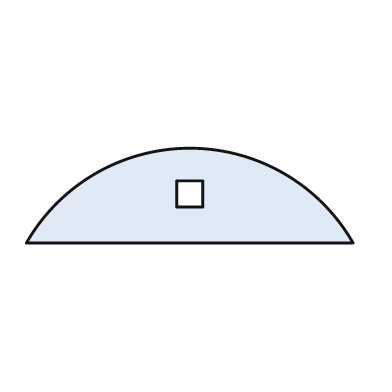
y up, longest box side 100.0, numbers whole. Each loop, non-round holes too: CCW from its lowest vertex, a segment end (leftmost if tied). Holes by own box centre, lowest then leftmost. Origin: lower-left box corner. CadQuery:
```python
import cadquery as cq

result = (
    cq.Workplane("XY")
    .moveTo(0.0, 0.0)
    .lineTo(100.0, 0.0)
    .threePointArc((50.0, 29.0), (0.0, 0.0))
    .close()
    .moveTo(46.0, 11.0)
    .lineTo(54.0, 11.0)
    .lineTo(54.0, 19.0)
    .lineTo(46.0, 19.0)
    .close()
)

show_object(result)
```